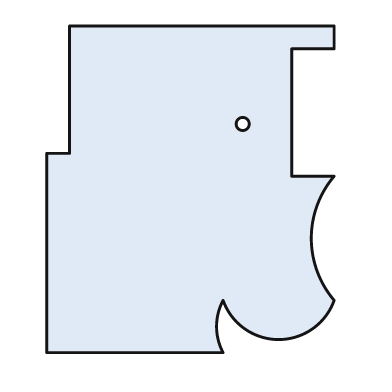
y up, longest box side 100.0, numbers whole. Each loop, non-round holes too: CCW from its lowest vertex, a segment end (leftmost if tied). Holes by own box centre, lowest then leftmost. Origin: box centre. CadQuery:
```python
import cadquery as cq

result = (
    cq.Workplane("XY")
    .moveTo(-44.0, -50.0)
    .lineTo(10.0, -50.0)
    .threePointArc((8.0, -42.0), (10.0, -34.0))
    .threePointArc((27.0, -46.0), (44.0, -34.0))
    .threePointArc((37.0, -15.0), (44.0, 4.0))
    .lineTo(31.0, 4.0)
    .lineTo(31.0, 43.0)
    .lineTo(44.0, 43.0)
    .lineTo(44.0, 50.0)
    .lineTo(-37.0, 50.0)
    .lineTo(-37.0, 11.0)
    .lineTo(-44.0, 11.0)
    .close()
    .moveTo(16.0, 20.0)
    .circle(2.0)
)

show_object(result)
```